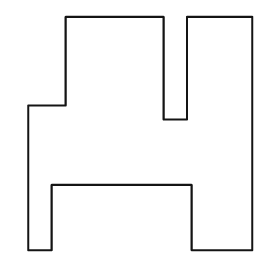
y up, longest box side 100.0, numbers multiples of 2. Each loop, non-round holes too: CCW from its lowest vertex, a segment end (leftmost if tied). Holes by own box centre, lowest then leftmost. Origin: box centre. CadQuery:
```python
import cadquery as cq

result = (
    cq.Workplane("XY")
    .moveTo(-48.0, -50.0)
    .lineTo(-38.0, -50.0)
    .lineTo(-38.0, -22.0)
    .lineTo(22.0, -22.0)
    .lineTo(22.0, -50.0)
    .lineTo(48.0, -50.0)
    .lineTo(48.0, 50.0)
    .lineTo(20.0, 50.0)
    .lineTo(20.0, 6.0)
    .lineTo(10.0, 6.0)
    .lineTo(10.0, 50.0)
    .lineTo(-32.0, 50.0)
    .lineTo(-32.0, 12.0)
    .lineTo(-48.0, 12.0)
    .close()
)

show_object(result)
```